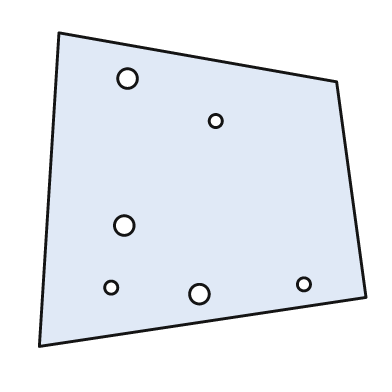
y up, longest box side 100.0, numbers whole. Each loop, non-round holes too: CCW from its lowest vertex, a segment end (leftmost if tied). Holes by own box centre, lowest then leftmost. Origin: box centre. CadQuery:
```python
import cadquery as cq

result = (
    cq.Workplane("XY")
    .moveTo(-50.0, -48.0)
    .lineTo(50.0, -33.0)
    .lineTo(41.0, 33.0)
    .lineTo(-44.0, 48.0)
    .close()
    .moveTo(-1.0, -32.0)
    .circle(3.0)
    .moveTo(-28.0, -30.0)
    .circle(2.0)
    .moveTo(31.0, -29.0)
    .circle(2.0)
    .moveTo(-24.0, -11.0)
    .circle(3.0)
    .moveTo(4.0, 21.0)
    .circle(2.0)
    .moveTo(-23.0, 34.0)
    .circle(3.0)
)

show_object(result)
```